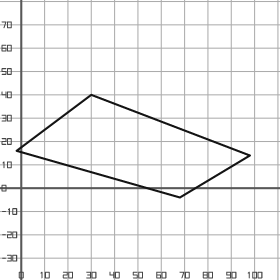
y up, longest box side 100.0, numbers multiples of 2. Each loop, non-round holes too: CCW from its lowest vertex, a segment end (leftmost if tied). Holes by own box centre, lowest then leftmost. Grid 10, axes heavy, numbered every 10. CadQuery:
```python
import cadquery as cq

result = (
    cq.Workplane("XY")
    .moveTo(68.0, -4.0)
    .lineTo(98.0, 14.0)
    .lineTo(30.0, 40.0)
    .lineTo(-2.0, 16.0)
    .close()
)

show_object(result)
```